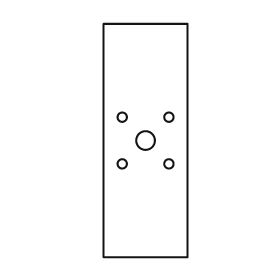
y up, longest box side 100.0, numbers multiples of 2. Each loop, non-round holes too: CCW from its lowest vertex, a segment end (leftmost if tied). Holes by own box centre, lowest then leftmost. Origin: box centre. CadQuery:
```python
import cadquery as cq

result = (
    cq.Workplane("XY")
    .moveTo(-18.0, -50.0)
    .lineTo(18.0, -50.0)
    .lineTo(18.0, 50.0)
    .lineTo(-18.0, 50.0)
    .close()
    .moveTo(-10.0, -10.0)
    .circle(2.0)
    .moveTo(10.0, -10.0)
    .circle(2.0)
    .moveTo(0.0, 0.0)
    .circle(4.0)
    .moveTo(-10.0, 10.0)
    .circle(2.0)
    .moveTo(10.0, 10.0)
    .circle(2.0)
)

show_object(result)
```